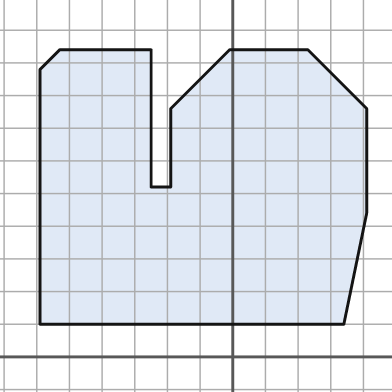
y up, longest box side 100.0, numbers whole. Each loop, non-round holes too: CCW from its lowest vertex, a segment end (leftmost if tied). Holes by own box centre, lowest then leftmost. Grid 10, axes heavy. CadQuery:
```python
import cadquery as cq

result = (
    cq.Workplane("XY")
    .moveTo(-59.0, 10.0)
    .lineTo(34.0, 10.0)
    .lineTo(41.0, 44.0)
    .lineTo(41.0, 76.0)
    .lineTo(23.0, 94.0)
    .lineTo(-1.0, 94.0)
    .lineTo(-19.0, 76.0)
    .lineTo(-19.0, 52.0)
    .lineTo(-25.0, 52.0)
    .lineTo(-25.0, 94.0)
    .lineTo(-53.0, 94.0)
    .lineTo(-59.0, 88.0)
    .close()
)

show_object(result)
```